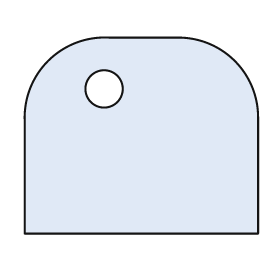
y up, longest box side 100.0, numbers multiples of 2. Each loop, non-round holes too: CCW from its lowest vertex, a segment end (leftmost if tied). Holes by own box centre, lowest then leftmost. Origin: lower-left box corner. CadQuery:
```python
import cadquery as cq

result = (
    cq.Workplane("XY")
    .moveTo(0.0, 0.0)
    .lineTo(100.0, 0.0)
    .lineTo(100.0, 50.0)
    .threePointArc((90.0, 74.0), (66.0, 84.0))
    .lineTo(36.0, 84.0)
    .threePointArc((10.0, 74.0), (0.0, 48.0))
    .close()
    .moveTo(34.0, 62.0)
    .circle(8.0)
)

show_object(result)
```